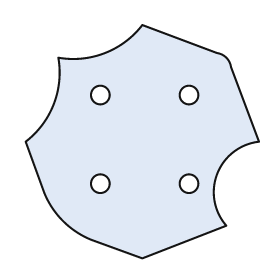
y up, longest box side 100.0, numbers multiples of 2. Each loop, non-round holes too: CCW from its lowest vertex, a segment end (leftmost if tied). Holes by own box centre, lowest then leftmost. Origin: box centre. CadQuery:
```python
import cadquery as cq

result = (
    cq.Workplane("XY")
    .moveTo(0.0, -50.0)
    .lineTo(36.0, -36.0)
    .threePointArc((32.0, -14.0), (50.0, 0.0))
    .lineTo(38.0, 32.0)
    .threePointArc((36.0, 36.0), (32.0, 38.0))
    .lineTo(0.0, 50.0)
    .threePointArc((-16.0, 38.0), (-36.0, 36.0))
    .threePointArc((-38.0, 16.0), (-50.0, 0.0))
    .lineTo(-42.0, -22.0)
    .threePointArc((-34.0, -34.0), (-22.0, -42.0))
    .close()
    .moveTo(-18.0, -18.0)
    .circle(4.0)
    .moveTo(20.0, -18.0)
    .circle(4.0)
    .moveTo(-18.0, 20.0)
    .circle(4.0)
    .moveTo(20.0, 20.0)
    .circle(4.0)
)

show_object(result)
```